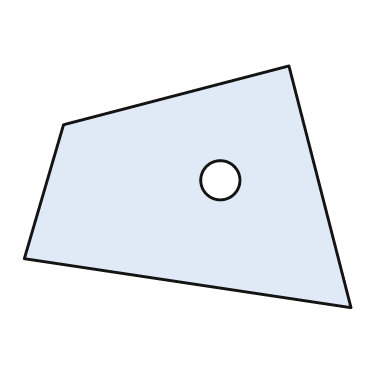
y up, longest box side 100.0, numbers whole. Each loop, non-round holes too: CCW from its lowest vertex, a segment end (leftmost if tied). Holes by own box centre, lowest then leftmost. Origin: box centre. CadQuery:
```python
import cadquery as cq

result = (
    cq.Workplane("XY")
    .moveTo(50.0, -37.0)
    .lineTo(31.0, 37.0)
    .lineTo(-38.0, 19.0)
    .lineTo(-50.0, -22.0)
    .close()
    .moveTo(10.0, 2.0)
    .circle(6.0)
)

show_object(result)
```